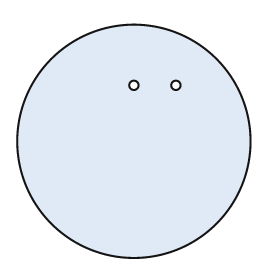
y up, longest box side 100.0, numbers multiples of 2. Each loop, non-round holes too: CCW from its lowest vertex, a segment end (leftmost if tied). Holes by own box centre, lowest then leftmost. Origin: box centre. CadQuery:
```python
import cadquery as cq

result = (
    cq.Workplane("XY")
    .moveTo(0.0, 0.0)
    .circle(50.0)
    .moveTo(0.0, 24.0)
    .circle(2.0)
    .moveTo(18.0, 24.0)
    .circle(2.0)
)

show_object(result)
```